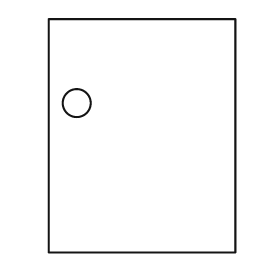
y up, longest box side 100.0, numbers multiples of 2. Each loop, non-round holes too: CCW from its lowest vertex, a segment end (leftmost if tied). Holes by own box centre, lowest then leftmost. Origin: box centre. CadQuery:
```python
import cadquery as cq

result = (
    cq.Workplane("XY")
    .moveTo(-40.0, -50.0)
    .lineTo(40.0, -50.0)
    .lineTo(40.0, 50.0)
    .lineTo(-40.0, 50.0)
    .close()
    .moveTo(-28.0, 14.0)
    .circle(6.0)
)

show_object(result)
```